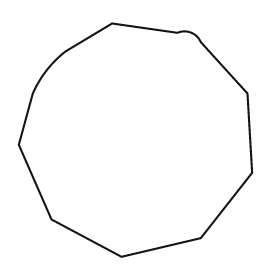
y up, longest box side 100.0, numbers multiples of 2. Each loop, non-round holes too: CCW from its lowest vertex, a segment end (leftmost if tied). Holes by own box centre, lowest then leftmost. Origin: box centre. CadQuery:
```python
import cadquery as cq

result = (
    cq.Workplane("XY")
    .moveTo(-6.0, -50.0)
    .lineTo(28.0, -42.0)
    .lineTo(50.0, -14.0)
    .lineTo(48.0, 20.0)
    .lineTo(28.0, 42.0)
    .threePointArc((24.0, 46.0), (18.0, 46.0))
    .lineTo(-10.0, 50.0)
    .lineTo(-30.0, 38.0)
    .threePointArc((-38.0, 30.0), (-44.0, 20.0))
    .lineTo(-50.0, -2.0)
    .lineTo(-36.0, -34.0)
    .close()
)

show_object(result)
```